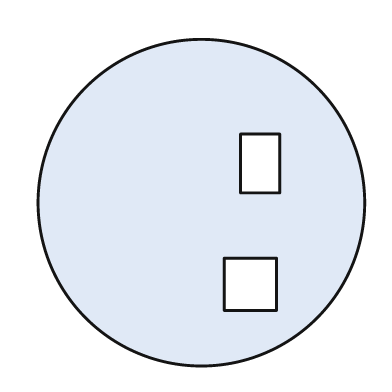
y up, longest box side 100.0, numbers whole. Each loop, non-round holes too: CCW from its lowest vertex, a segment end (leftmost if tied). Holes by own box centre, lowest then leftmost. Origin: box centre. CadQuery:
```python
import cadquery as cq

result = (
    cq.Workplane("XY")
    .moveTo(0.0, 0.0)
    .circle(50.0)
    .moveTo(7.0, -33.0)
    .lineTo(23.0, -33.0)
    .lineTo(23.0, -17.0)
    .lineTo(7.0, -17.0)
    .close()
    .moveTo(12.0, 3.0)
    .lineTo(24.0, 3.0)
    .lineTo(24.0, 21.0)
    .lineTo(12.0, 21.0)
    .close()
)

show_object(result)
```